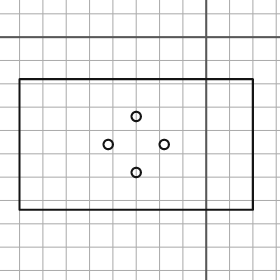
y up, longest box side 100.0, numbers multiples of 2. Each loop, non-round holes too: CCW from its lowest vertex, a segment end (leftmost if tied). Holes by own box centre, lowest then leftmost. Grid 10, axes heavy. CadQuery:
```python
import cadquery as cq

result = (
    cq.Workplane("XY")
    .moveTo(-80.0, -74.0)
    .lineTo(20.0, -74.0)
    .lineTo(20.0, -18.0)
    .lineTo(-80.0, -18.0)
    .close()
    .moveTo(-30.0, -58.0)
    .circle(2.0)
    .moveTo(-42.0, -46.0)
    .circle(2.0)
    .moveTo(-18.0, -46.0)
    .circle(2.0)
    .moveTo(-30.0, -34.0)
    .circle(2.0)
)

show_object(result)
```